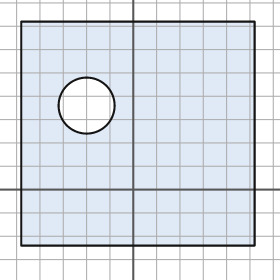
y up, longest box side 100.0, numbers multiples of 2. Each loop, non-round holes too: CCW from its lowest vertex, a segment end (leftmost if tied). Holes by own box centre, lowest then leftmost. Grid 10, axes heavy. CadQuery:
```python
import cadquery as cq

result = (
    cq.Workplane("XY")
    .moveTo(-48.0, -24.0)
    .lineTo(52.0, -24.0)
    .lineTo(52.0, 72.0)
    .lineTo(-48.0, 72.0)
    .close()
    .moveTo(-20.0, 36.0)
    .circle(12.0)
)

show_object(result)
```